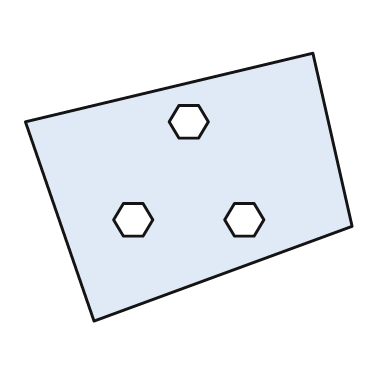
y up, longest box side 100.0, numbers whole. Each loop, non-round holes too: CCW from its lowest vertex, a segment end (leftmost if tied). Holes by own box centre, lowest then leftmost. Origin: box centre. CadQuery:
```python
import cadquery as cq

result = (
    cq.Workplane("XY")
    .moveTo(-29.0, -41.0)
    .lineTo(50.0, -12.0)
    .lineTo(38.0, 41.0)
    .lineTo(-50.0, 20.0)
    .close()
    .moveTo(-20.0, -15.0)
    .lineTo(-14.0, -15.0)
    .lineTo(-11.0, -10.0)
    .lineTo(-14.0, -5.0)
    .lineTo(-20.0, -5.0)
    .lineTo(-23.0, -10.0)
    .close()
    .moveTo(14.0, -15.0)
    .lineTo(20.0, -15.0)
    .lineTo(23.0, -10.0)
    .lineTo(20.0, -5.0)
    .lineTo(14.0, -5.0)
    .lineTo(11.0, -10.0)
    .close()
    .moveTo(-3.0, 15.0)
    .lineTo(3.0, 15.0)
    .lineTo(6.0, 20.0)
    .lineTo(3.0, 25.0)
    .lineTo(-3.0, 25.0)
    .lineTo(-6.0, 20.0)
    .close()
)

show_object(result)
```